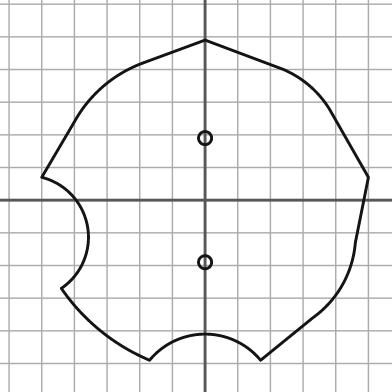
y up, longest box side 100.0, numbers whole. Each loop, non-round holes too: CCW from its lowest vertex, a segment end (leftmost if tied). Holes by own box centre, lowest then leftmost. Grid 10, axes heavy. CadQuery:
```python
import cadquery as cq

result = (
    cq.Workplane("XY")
    .moveTo(-17.0, -49.0)
    .threePointArc((0.0, -41.0), (17.0, -49.0))
    .lineTo(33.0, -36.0)
    .threePointArc((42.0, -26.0), (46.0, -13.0))
    .lineTo(50.0, 7.0)
    .lineTo(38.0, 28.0)
    .threePointArc((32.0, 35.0), (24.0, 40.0))
    .lineTo(0.0, 49.0)
    .lineTo(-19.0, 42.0)
    .threePointArc((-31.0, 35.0), (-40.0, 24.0))
    .lineTo(-50.0, 7.0)
    .threePointArc((-36.0, -8.0), (-44.0, -27.0))
    .threePointArc((-32.0, -40.0), (-17.0, -49.0))
    .close()
    .moveTo(0.0, -19.0)
    .circle(2.0)
    .moveTo(0.0, 19.0)
    .circle(2.0)
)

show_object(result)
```